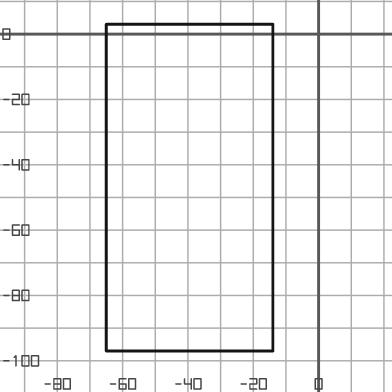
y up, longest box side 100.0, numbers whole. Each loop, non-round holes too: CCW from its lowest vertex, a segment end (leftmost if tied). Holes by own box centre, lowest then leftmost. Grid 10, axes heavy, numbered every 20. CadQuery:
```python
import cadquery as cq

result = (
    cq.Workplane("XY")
    .moveTo(-65.0, -97.0)
    .lineTo(-14.0, -97.0)
    .lineTo(-14.0, 3.0)
    .lineTo(-65.0, 3.0)
    .close()
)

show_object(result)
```